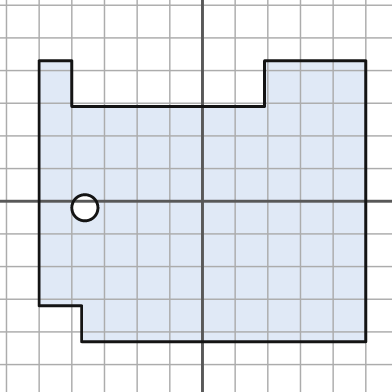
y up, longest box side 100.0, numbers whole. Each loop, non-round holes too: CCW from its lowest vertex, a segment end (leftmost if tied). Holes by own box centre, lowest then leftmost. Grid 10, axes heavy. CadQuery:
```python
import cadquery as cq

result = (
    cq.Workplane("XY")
    .moveTo(-37.0, -43.0)
    .lineTo(50.0, -43.0)
    .lineTo(50.0, 43.0)
    .lineTo(19.0, 43.0)
    .lineTo(19.0, 29.0)
    .lineTo(-40.0, 29.0)
    .lineTo(-40.0, 43.0)
    .lineTo(-50.0, 43.0)
    .lineTo(-50.0, -32.0)
    .lineTo(-37.0, -32.0)
    .close()
    .moveTo(-36.0, -2.0)
    .circle(4.0)
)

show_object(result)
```